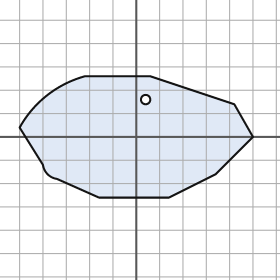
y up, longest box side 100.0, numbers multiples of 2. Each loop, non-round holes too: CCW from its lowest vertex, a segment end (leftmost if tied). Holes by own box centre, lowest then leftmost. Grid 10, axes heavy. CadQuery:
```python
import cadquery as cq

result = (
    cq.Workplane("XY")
    .moveTo(-16.0, -26.0)
    .lineTo(14.0, -26.0)
    .lineTo(34.0, -16.0)
    .lineTo(50.0, 0.0)
    .lineTo(42.0, 14.0)
    .lineTo(6.0, 26.0)
    .lineTo(-22.0, 26.0)
    .threePointArc((-38.0, 18.0), (-50.0, 4.0))
    .lineTo(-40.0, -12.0)
    .threePointArc((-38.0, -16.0), (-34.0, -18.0))
    .close()
    .moveTo(4.0, 16.0)
    .circle(2.0)
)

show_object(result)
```